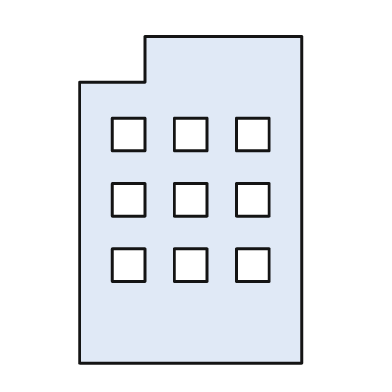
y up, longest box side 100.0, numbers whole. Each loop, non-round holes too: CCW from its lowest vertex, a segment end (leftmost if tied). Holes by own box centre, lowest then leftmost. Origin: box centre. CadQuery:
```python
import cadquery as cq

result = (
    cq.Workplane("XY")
    .moveTo(-34.0, -50.0)
    .lineTo(34.0, -50.0)
    .lineTo(34.0, 50.0)
    .lineTo(-14.0, 50.0)
    .lineTo(-14.0, 36.0)
    .lineTo(-34.0, 36.0)
    .close()
    .moveTo(-24.0, -25.0)
    .lineTo(-14.0, -25.0)
    .lineTo(-14.0, -15.0)
    .lineTo(-24.0, -15.0)
    .close()
    .moveTo(-5.0, -25.0)
    .lineTo(5.0, -25.0)
    .lineTo(5.0, -15.0)
    .lineTo(-5.0, -15.0)
    .close()
    .moveTo(14.0, -25.0)
    .lineTo(24.0, -25.0)
    .lineTo(24.0, -15.0)
    .lineTo(14.0, -15.0)
    .close()
    .moveTo(-24.0, -5.0)
    .lineTo(-14.0, -5.0)
    .lineTo(-14.0, 5.0)
    .lineTo(-24.0, 5.0)
    .close()
    .moveTo(-5.0, -5.0)
    .lineTo(5.0, -5.0)
    .lineTo(5.0, 5.0)
    .lineTo(-5.0, 5.0)
    .close()
    .moveTo(14.0, -5.0)
    .lineTo(24.0, -5.0)
    .lineTo(24.0, 5.0)
    .lineTo(14.0, 5.0)
    .close()
    .moveTo(-24.0, 15.0)
    .lineTo(-14.0, 15.0)
    .lineTo(-14.0, 25.0)
    .lineTo(-24.0, 25.0)
    .close()
    .moveTo(-5.0, 15.0)
    .lineTo(5.0, 15.0)
    .lineTo(5.0, 25.0)
    .lineTo(-5.0, 25.0)
    .close()
    .moveTo(14.0, 15.0)
    .lineTo(24.0, 15.0)
    .lineTo(24.0, 25.0)
    .lineTo(14.0, 25.0)
    .close()
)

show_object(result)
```